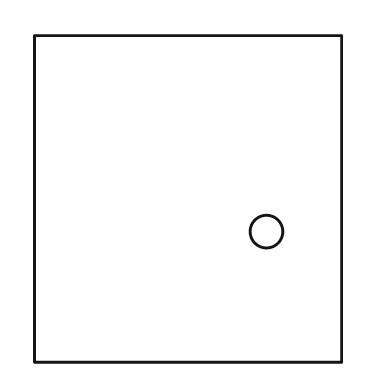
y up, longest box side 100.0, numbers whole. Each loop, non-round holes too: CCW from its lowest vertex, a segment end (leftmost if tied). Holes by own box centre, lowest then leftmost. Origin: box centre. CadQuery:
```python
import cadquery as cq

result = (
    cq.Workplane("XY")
    .moveTo(-47.0, -50.0)
    .lineTo(47.0, -50.0)
    .lineTo(47.0, 50.0)
    .lineTo(-47.0, 50.0)
    .close()
    .moveTo(24.0, -10.0)
    .circle(5.0)
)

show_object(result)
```